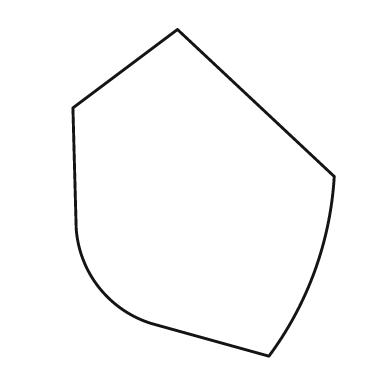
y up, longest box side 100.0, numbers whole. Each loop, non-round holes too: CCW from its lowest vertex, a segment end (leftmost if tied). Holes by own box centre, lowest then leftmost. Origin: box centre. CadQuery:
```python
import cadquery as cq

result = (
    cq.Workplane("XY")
    .moveTo(20.0, -50.0)
    .threePointArc((34.0, -24.0), (40.0, 5.0))
    .lineTo(-8.0, 50.0)
    .lineTo(-40.0, 26.0)
    .lineTo(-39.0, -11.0)
    .threePointArc((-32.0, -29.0), (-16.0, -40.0))
    .close()
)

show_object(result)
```